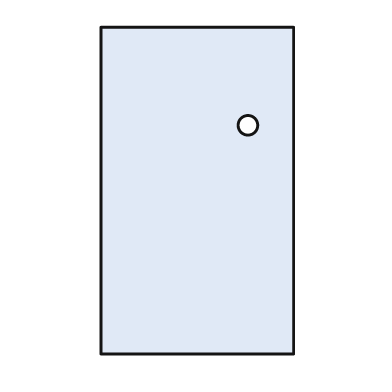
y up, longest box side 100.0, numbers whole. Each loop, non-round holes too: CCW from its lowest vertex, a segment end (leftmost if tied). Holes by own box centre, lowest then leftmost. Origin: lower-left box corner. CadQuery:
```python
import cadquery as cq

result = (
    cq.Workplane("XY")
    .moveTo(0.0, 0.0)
    .lineTo(59.0, 0.0)
    .lineTo(59.0, 100.0)
    .lineTo(0.0, 100.0)
    .close()
    .moveTo(45.0, 70.0)
    .circle(3.0)
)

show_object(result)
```